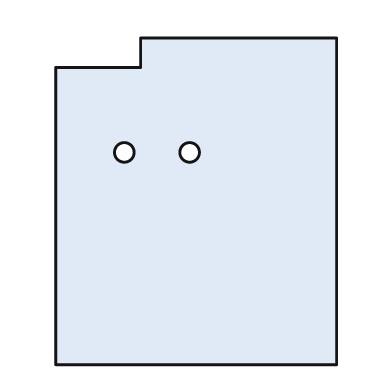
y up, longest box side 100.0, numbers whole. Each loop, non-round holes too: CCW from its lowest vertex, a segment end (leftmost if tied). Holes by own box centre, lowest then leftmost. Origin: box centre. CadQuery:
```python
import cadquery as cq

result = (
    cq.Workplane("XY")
    .moveTo(-43.0, -50.0)
    .lineTo(43.0, -50.0)
    .lineTo(43.0, 50.0)
    .lineTo(-17.0, 50.0)
    .lineTo(-17.0, 41.0)
    .lineTo(-43.0, 41.0)
    .close()
    .moveTo(-22.0, 15.0)
    .circle(3.0)
    .moveTo(-2.0, 15.0)
    .circle(3.0)
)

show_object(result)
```